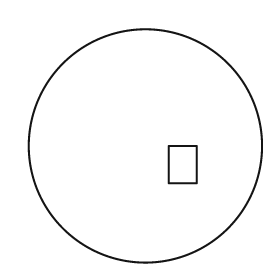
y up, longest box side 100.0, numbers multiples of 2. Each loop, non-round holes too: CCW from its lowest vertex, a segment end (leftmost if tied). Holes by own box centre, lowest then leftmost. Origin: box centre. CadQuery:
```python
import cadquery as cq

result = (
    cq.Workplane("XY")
    .moveTo(0.0, 0.0)
    .circle(50.0)
    .moveTo(10.0, -16.0)
    .lineTo(22.0, -16.0)
    .lineTo(22.0, 0.0)
    .lineTo(10.0, 0.0)
    .close()
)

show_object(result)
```